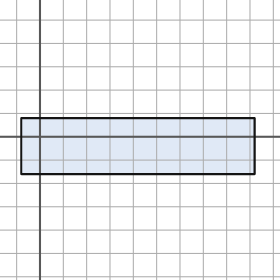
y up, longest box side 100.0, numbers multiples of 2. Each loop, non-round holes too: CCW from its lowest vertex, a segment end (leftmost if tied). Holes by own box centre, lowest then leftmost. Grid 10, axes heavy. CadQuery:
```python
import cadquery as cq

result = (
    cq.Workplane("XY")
    .moveTo(-8.0, -16.0)
    .lineTo(92.0, -16.0)
    .lineTo(92.0, 8.0)
    .lineTo(-8.0, 8.0)
    .close()
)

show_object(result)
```